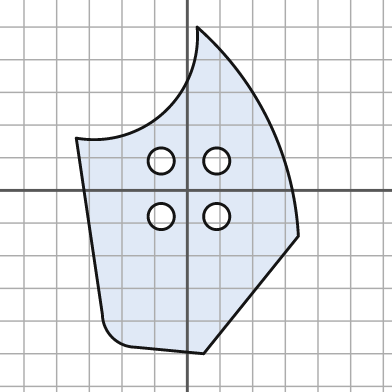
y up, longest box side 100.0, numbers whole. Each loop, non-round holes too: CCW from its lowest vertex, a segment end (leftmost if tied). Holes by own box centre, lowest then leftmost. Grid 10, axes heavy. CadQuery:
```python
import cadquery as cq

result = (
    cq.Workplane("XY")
    .moveTo(5.0, -50.0)
    .lineTo(34.0, -14.0)
    .threePointArc((25.0, 21.0), (3.0, 50.0))
    .threePointArc((-7.0, 24.0), (-34.0, 16.0))
    .lineTo(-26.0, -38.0)
    .threePointArc((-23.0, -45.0), (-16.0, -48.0))
    .close()
    .moveTo(-8.0, -8.0)
    .circle(4.0)
    .moveTo(9.0, -8.0)
    .circle(4.0)
    .moveTo(-8.0, 9.0)
    .circle(4.0)
    .moveTo(9.0, 9.0)
    .circle(4.0)
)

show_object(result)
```